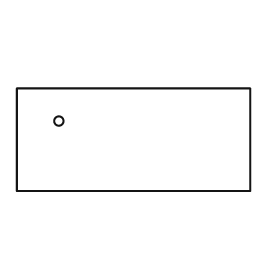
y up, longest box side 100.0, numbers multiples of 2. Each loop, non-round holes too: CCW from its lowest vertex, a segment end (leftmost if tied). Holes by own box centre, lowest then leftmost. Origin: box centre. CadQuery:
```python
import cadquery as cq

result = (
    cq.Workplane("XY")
    .moveTo(-50.0, -22.0)
    .lineTo(50.0, -22.0)
    .lineTo(50.0, 22.0)
    .lineTo(-50.0, 22.0)
    .close()
    .moveTo(-32.0, 8.0)
    .circle(2.0)
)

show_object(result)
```